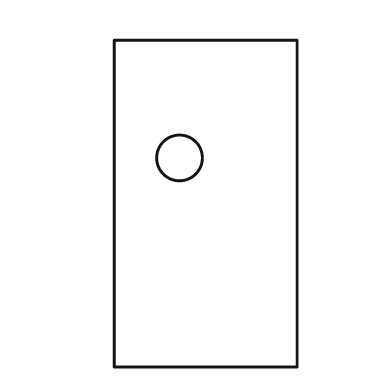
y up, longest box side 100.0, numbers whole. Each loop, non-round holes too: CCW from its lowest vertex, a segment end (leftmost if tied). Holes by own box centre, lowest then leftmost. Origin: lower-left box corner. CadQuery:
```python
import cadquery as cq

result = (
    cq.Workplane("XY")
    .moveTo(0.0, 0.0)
    .lineTo(56.0, 0.0)
    .lineTo(56.0, 100.0)
    .lineTo(0.0, 100.0)
    .close()
    .moveTo(20.0, 64.0)
    .circle(7.0)
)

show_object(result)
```